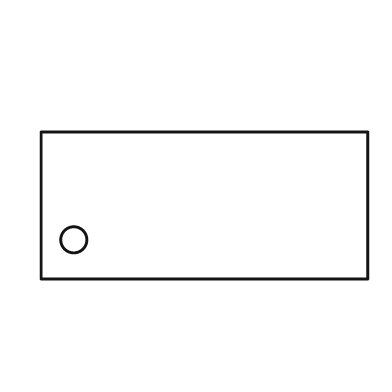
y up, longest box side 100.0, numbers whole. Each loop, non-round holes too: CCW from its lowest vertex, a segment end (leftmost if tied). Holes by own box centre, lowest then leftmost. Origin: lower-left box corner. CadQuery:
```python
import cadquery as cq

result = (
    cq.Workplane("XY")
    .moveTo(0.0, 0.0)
    .lineTo(100.0, 0.0)
    .lineTo(100.0, 45.0)
    .lineTo(0.0, 45.0)
    .close()
    .moveTo(10.0, 12.0)
    .circle(4.0)
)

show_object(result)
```